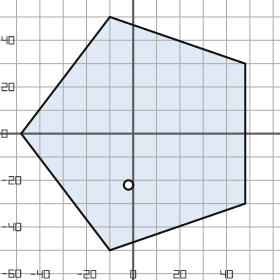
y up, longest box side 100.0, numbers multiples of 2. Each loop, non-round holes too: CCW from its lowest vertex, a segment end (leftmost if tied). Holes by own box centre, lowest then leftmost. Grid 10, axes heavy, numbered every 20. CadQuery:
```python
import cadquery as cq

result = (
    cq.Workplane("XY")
    .moveTo(-10.0, -50.0)
    .lineTo(48.0, -30.0)
    .lineTo(48.0, 30.0)
    .lineTo(-10.0, 50.0)
    .lineTo(-48.0, 0.0)
    .close()
    .moveTo(-2.0, -22.0)
    .circle(2.0)
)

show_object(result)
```